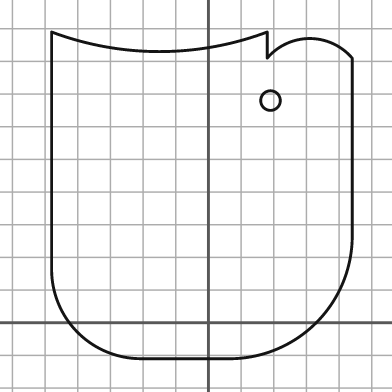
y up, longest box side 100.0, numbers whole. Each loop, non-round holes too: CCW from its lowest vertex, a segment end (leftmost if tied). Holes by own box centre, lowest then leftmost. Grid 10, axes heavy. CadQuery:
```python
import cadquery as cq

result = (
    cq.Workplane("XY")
    .moveTo(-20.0, -11.0)
    .lineTo(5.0, -11.0)
    .threePointArc((33.0, 0.0), (44.0, 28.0))
    .lineTo(44.0, 81.0)
    .threePointArc((31.0, 87.0), (18.0, 81.0))
    .lineTo(18.0, 89.0)
    .threePointArc((-15.0, 83.0), (-48.0, 89.0))
    .lineTo(-48.0, 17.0)
    .threePointArc((-40.0, -3.0), (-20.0, -11.0))
    .close()
    .moveTo(19.0, 68.0)
    .circle(3.0)
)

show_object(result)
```